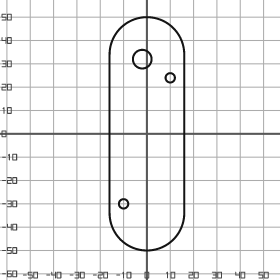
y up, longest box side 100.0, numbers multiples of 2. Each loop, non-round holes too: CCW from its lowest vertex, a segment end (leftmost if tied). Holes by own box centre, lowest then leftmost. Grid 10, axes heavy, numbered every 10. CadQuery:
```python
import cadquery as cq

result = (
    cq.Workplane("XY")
    .moveTo(-16.0, -34.0)
    .threePointArc((0.0, -50.0), (16.0, -34.0))
    .lineTo(16.0, 34.0)
    .threePointArc((0.0, 50.0), (-16.0, 34.0))
    .close()
    .moveTo(-10.0, -30.0)
    .circle(2.0)
    .moveTo(10.0, 24.0)
    .circle(2.0)
    .moveTo(-2.0, 32.0)
    .circle(4.0)
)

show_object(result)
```